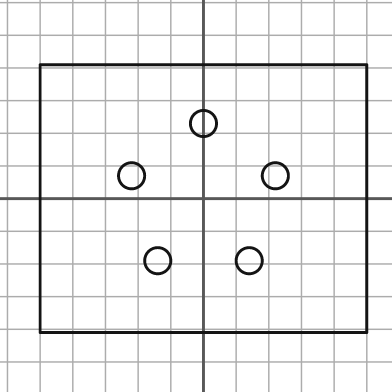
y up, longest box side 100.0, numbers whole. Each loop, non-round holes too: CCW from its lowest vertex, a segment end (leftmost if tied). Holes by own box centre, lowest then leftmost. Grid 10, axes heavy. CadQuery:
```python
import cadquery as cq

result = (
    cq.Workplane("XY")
    .moveTo(-50.0, -41.0)
    .lineTo(50.0, -41.0)
    .lineTo(50.0, 41.0)
    .lineTo(-50.0, 41.0)
    .close()
    .moveTo(-14.0, -19.0)
    .circle(4.0)
    .moveTo(14.0, -19.0)
    .circle(4.0)
    .moveTo(-22.0, 7.0)
    .circle(4.0)
    .moveTo(22.0, 7.0)
    .circle(4.0)
    .moveTo(0.0, 23.0)
    .circle(4.0)
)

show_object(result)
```